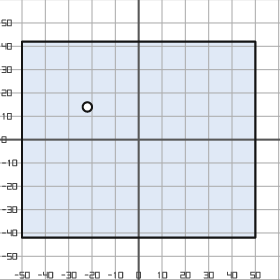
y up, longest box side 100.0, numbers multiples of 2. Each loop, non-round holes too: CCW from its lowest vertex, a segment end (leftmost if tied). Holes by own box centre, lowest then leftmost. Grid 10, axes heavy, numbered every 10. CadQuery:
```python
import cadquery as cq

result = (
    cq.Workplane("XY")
    .moveTo(-50.0, -42.0)
    .lineTo(50.0, -42.0)
    .lineTo(50.0, 42.0)
    .lineTo(-50.0, 42.0)
    .close()
    .moveTo(-22.0, 14.0)
    .circle(2.0)
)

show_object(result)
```